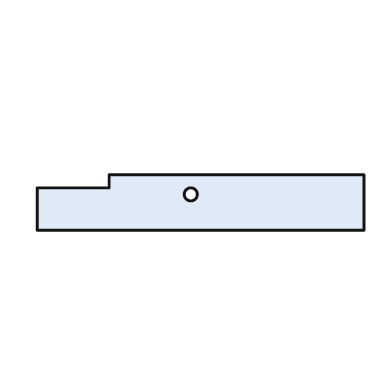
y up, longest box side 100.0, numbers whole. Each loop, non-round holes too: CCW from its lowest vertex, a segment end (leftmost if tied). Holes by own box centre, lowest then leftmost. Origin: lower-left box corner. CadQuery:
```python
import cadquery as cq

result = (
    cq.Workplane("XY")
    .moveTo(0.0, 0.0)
    .lineTo(100.0, 0.0)
    .lineTo(100.0, 17.0)
    .lineTo(22.0, 17.0)
    .lineTo(22.0, 13.0)
    .lineTo(0.0, 13.0)
    .close()
    .moveTo(47.0, 11.0)
    .circle(2.0)
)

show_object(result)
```